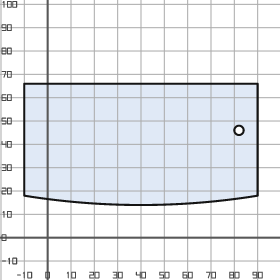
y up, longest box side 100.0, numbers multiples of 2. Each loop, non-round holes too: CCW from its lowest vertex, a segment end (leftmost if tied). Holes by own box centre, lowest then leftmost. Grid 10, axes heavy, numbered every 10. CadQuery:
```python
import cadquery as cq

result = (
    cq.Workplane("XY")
    .moveTo(-10.0, 18.0)
    .threePointArc((40.0, 14.0), (90.0, 18.0))
    .lineTo(90.0, 66.0)
    .lineTo(-10.0, 66.0)
    .close()
    .moveTo(82.0, 46.0)
    .circle(2.0)
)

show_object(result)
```